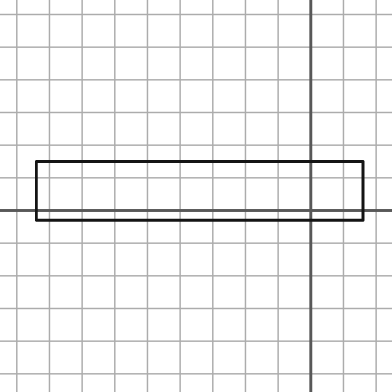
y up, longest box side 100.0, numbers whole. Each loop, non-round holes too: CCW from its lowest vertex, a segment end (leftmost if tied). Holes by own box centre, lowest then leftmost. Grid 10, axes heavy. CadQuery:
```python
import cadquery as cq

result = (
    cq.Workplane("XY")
    .moveTo(-84.0, -3.0)
    .lineTo(16.0, -3.0)
    .lineTo(16.0, 15.0)
    .lineTo(-84.0, 15.0)
    .close()
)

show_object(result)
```